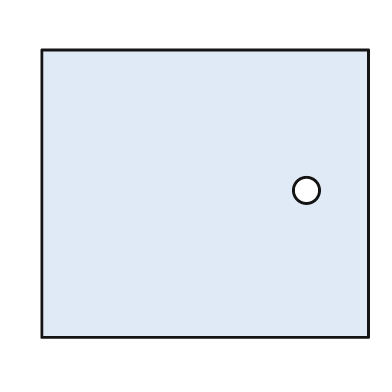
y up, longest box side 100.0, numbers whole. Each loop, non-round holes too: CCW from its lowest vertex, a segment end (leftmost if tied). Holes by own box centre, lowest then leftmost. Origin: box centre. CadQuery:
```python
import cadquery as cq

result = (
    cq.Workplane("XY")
    .moveTo(-50.0, -44.0)
    .lineTo(50.0, -44.0)
    .lineTo(50.0, 44.0)
    .lineTo(-50.0, 44.0)
    .close()
    .moveTo(31.0, 1.0)
    .circle(4.0)
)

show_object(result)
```